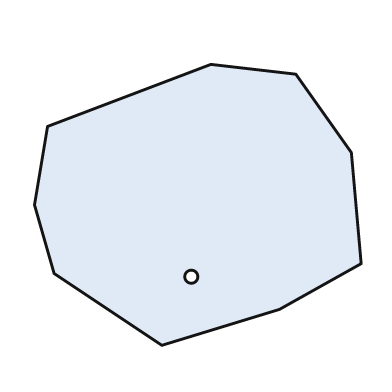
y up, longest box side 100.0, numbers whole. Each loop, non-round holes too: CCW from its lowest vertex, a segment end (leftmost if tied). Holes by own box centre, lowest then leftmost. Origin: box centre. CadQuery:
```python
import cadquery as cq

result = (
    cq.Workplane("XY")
    .moveTo(-11.0, -43.0)
    .lineTo(25.0, -32.0)
    .lineTo(50.0, -18.0)
    .lineTo(47.0, 16.0)
    .lineTo(30.0, 40.0)
    .lineTo(4.0, 43.0)
    .lineTo(-46.0, 24.0)
    .lineTo(-50.0, 0.0)
    .lineTo(-44.0, -21.0)
    .close()
    .moveTo(-2.0, -22.0)
    .circle(2.0)
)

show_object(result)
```